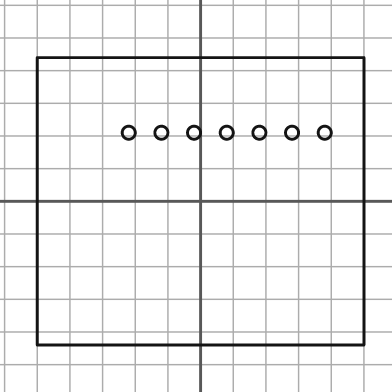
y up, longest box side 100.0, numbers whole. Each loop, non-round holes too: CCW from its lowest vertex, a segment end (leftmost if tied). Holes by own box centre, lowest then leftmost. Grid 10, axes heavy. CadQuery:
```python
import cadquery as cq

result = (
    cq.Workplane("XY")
    .moveTo(-50.0, -44.0)
    .lineTo(50.0, -44.0)
    .lineTo(50.0, 44.0)
    .lineTo(-50.0, 44.0)
    .close()
    .moveTo(-22.0, 21.0)
    .circle(2.0)
    .moveTo(-12.0, 21.0)
    .circle(2.0)
    .moveTo(-2.0, 21.0)
    .circle(2.0)
    .moveTo(8.0, 21.0)
    .circle(2.0)
    .moveTo(18.0, 21.0)
    .circle(2.0)
    .moveTo(28.0, 21.0)
    .circle(2.0)
    .moveTo(38.0, 21.0)
    .circle(2.0)
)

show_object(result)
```